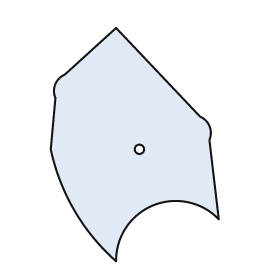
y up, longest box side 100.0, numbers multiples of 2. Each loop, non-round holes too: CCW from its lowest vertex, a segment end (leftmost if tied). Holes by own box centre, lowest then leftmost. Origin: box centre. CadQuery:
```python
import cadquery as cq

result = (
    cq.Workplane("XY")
    .moveTo(-8.0, -50.0)
    .threePointArc((8.0, -26.0), (36.0, -32.0))
    .lineTo(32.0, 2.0)
    .threePointArc((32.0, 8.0), (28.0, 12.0))
    .lineTo(-8.0, 50.0)
    .lineTo(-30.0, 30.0)
    .threePointArc((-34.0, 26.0), (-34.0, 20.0))
    .lineTo(-36.0, -2.0)
    .threePointArc((-26.0, -28.0), (-8.0, -50.0))
    .close()
    .moveTo(2.0, -2.0)
    .circle(2.0)
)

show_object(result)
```